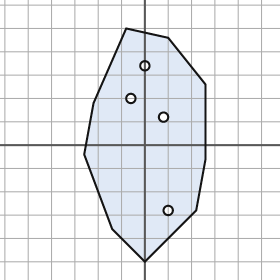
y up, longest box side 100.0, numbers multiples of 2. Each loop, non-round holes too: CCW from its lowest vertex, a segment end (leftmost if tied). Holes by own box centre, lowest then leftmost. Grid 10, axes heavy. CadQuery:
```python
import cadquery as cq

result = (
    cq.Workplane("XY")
    .moveTo(0.0, -50.0)
    .lineTo(22.0, -28.0)
    .lineTo(26.0, -6.0)
    .lineTo(26.0, 26.0)
    .lineTo(10.0, 46.0)
    .lineTo(-8.0, 50.0)
    .lineTo(-22.0, 18.0)
    .lineTo(-26.0, -4.0)
    .lineTo(-14.0, -36.0)
    .close()
    .moveTo(10.0, -28.0)
    .circle(2.0)
    .moveTo(8.0, 12.0)
    .circle(2.0)
    .moveTo(-6.0, 20.0)
    .circle(2.0)
    .moveTo(0.0, 34.0)
    .circle(2.0)
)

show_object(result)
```